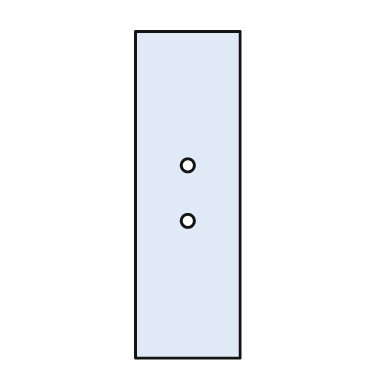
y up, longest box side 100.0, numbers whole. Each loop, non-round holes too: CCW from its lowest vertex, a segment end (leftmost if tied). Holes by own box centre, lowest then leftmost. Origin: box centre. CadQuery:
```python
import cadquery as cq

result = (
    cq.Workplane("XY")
    .moveTo(-16.0, -50.0)
    .lineTo(16.0, -50.0)
    .lineTo(16.0, 50.0)
    .lineTo(-16.0, 50.0)
    .close()
    .moveTo(0.0, -8.0)
    .circle(2.0)
    .moveTo(0.0, 9.0)
    .circle(2.0)
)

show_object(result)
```